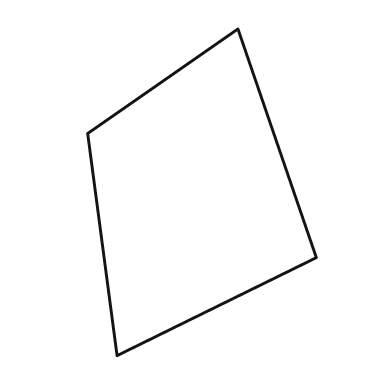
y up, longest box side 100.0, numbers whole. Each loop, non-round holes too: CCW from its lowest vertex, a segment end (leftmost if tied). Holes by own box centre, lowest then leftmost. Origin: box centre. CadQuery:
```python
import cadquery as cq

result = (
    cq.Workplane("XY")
    .moveTo(-26.0, -50.0)
    .lineTo(35.0, -20.0)
    .lineTo(11.0, 50.0)
    .lineTo(-35.0, 18.0)
    .close()
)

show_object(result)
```